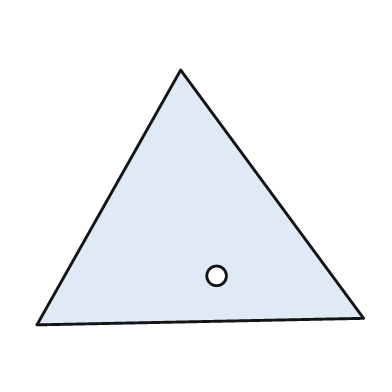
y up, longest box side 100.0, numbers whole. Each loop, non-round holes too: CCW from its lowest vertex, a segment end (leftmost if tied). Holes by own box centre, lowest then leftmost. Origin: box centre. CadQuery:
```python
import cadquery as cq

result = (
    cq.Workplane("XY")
    .moveTo(-50.0, -39.0)
    .lineTo(50.0, -37.0)
    .lineTo(-6.0, 39.0)
    .close()
    .moveTo(5.0, -24.0)
    .circle(3.0)
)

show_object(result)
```